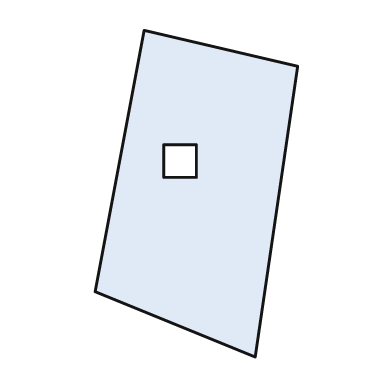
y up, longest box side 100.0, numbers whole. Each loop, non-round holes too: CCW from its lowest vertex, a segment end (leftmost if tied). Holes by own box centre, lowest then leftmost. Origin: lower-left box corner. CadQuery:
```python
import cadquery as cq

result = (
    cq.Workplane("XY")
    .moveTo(49.0, 0.0)
    .lineTo(62.0, 89.0)
    .lineTo(15.0, 100.0)
    .lineTo(0.0, 20.0)
    .close()
    .moveTo(21.0, 55.0)
    .lineTo(31.0, 55.0)
    .lineTo(31.0, 65.0)
    .lineTo(21.0, 65.0)
    .close()
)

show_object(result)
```